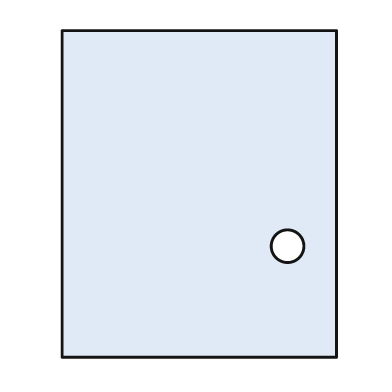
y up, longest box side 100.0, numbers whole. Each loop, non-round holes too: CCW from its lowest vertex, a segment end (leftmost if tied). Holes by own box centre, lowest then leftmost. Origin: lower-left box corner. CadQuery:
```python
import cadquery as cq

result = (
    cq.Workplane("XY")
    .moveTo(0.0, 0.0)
    .lineTo(84.0, 0.0)
    .lineTo(84.0, 100.0)
    .lineTo(0.0, 100.0)
    .close()
    .moveTo(69.0, 34.0)
    .circle(5.0)
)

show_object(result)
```